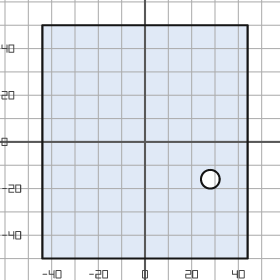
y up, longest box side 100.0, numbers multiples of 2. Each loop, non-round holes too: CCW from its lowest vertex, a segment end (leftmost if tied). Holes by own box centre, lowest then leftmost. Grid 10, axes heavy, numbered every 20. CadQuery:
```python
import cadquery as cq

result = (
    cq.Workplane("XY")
    .moveTo(-44.0, -50.0)
    .lineTo(44.0, -50.0)
    .lineTo(44.0, 50.0)
    .lineTo(-44.0, 50.0)
    .close()
    .moveTo(28.0, -16.0)
    .circle(4.0)
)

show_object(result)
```